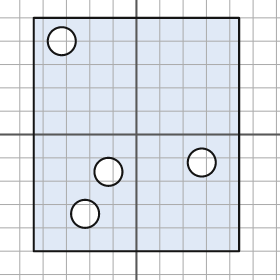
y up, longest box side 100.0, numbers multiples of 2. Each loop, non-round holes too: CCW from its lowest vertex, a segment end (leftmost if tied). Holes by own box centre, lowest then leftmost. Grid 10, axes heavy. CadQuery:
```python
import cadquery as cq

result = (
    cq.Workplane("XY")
    .moveTo(-44.0, -50.0)
    .lineTo(44.0, -50.0)
    .lineTo(44.0, 50.0)
    .lineTo(-44.0, 50.0)
    .close()
    .moveTo(-22.0, -34.0)
    .circle(6.0)
    .moveTo(-12.0, -16.0)
    .circle(6.0)
    .moveTo(28.0, -12.0)
    .circle(6.0)
    .moveTo(-32.0, 40.0)
    .circle(6.0)
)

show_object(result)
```